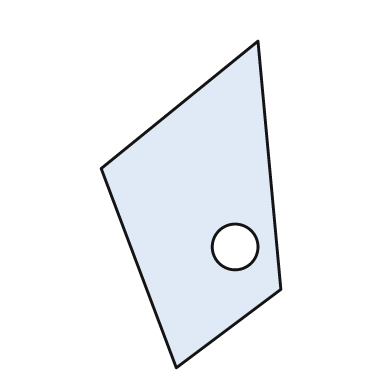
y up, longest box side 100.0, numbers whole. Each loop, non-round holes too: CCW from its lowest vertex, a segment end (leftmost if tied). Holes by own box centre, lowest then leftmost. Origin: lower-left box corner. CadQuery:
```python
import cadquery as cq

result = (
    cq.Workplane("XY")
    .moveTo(23.0, 0.0)
    .lineTo(55.0, 24.0)
    .lineTo(48.0, 100.0)
    .lineTo(0.0, 61.0)
    .close()
    .moveTo(41.0, 37.0)
    .circle(7.0)
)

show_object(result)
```